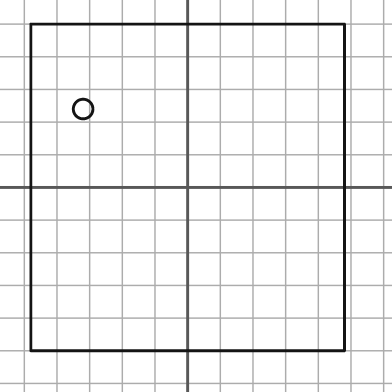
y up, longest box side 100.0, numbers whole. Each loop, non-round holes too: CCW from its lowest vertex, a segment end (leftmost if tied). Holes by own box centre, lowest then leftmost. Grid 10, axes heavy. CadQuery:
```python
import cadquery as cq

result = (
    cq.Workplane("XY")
    .moveTo(-48.0, -50.0)
    .lineTo(48.0, -50.0)
    .lineTo(48.0, 50.0)
    .lineTo(-48.0, 50.0)
    .close()
    .moveTo(-32.0, 24.0)
    .circle(3.0)
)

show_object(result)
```